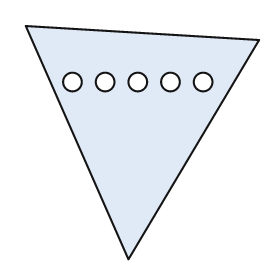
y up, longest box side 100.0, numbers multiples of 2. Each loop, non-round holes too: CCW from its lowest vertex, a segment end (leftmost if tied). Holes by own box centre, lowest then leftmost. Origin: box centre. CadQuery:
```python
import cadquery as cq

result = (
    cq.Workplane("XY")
    .moveTo(-6.0, -50.0)
    .lineTo(50.0, 44.0)
    .lineTo(-50.0, 50.0)
    .close()
    .moveTo(-30.0, 26.0)
    .circle(4.0)
    .moveTo(-16.0, 26.0)
    .circle(4.0)
    .moveTo(-2.0, 26.0)
    .circle(4.0)
    .moveTo(12.0, 26.0)
    .circle(4.0)
    .moveTo(26.0, 26.0)
    .circle(4.0)
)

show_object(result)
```